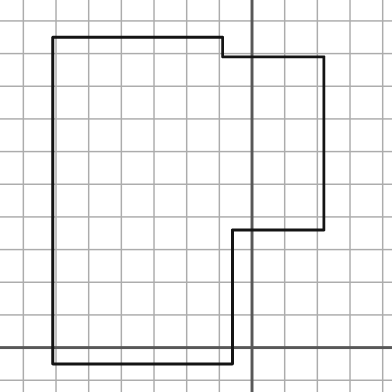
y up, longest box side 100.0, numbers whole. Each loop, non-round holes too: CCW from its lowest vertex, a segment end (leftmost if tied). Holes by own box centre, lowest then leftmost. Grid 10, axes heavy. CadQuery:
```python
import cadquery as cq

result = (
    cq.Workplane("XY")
    .moveTo(-61.0, -5.0)
    .lineTo(-6.0, -5.0)
    .lineTo(-6.0, 36.0)
    .lineTo(22.0, 36.0)
    .lineTo(22.0, 89.0)
    .lineTo(-9.0, 89.0)
    .lineTo(-9.0, 95.0)
    .lineTo(-61.0, 95.0)
    .close()
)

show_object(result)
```